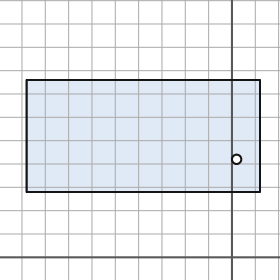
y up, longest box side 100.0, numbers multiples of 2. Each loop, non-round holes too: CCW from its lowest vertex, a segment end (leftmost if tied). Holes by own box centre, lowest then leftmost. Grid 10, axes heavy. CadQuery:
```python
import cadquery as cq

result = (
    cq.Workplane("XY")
    .moveTo(-88.0, 28.0)
    .lineTo(12.0, 28.0)
    .lineTo(12.0, 76.0)
    .lineTo(-88.0, 76.0)
    .close()
    .moveTo(2.0, 42.0)
    .circle(2.0)
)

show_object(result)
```